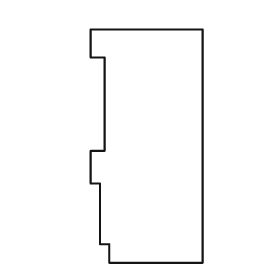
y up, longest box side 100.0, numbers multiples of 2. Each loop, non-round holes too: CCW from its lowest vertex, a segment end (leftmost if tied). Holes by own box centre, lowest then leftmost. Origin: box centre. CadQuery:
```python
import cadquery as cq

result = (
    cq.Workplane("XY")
    .moveTo(-16.0, -50.0)
    .lineTo(24.0, -50.0)
    .lineTo(24.0, 50.0)
    .lineTo(-24.0, 50.0)
    .lineTo(-24.0, 38.0)
    .lineTo(-18.0, 38.0)
    .lineTo(-18.0, -2.0)
    .lineTo(-24.0, -2.0)
    .lineTo(-24.0, -16.0)
    .lineTo(-20.0, -16.0)
    .lineTo(-20.0, -42.0)
    .lineTo(-16.0, -42.0)
    .close()
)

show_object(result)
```